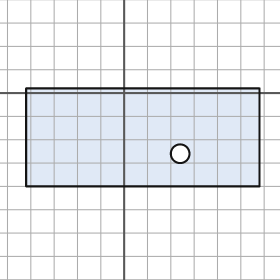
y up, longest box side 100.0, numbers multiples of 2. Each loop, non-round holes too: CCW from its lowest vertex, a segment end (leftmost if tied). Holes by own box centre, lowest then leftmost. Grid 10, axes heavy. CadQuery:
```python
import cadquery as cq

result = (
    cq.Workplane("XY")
    .moveTo(-42.0, -40.0)
    .lineTo(58.0, -40.0)
    .lineTo(58.0, 2.0)
    .lineTo(-42.0, 2.0)
    .close()
    .moveTo(24.0, -26.0)
    .circle(4.0)
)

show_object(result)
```